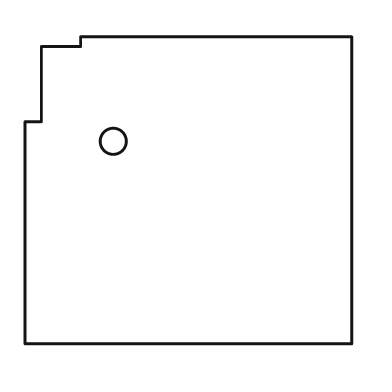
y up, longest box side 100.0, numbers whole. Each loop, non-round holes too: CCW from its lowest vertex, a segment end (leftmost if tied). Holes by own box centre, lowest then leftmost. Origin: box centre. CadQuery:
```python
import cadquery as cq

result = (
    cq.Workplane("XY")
    .moveTo(-50.0, -47.0)
    .lineTo(50.0, -47.0)
    .lineTo(50.0, 47.0)
    .lineTo(-33.0, 47.0)
    .lineTo(-33.0, 44.0)
    .lineTo(-45.0, 44.0)
    .lineTo(-45.0, 21.0)
    .lineTo(-50.0, 21.0)
    .close()
    .moveTo(-23.0, 15.0)
    .circle(4.0)
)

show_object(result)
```